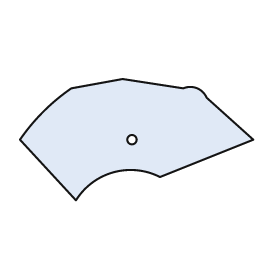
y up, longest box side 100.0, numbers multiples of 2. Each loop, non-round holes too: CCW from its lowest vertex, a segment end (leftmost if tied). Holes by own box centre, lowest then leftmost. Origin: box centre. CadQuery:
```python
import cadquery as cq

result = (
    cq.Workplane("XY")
    .moveTo(-26.0, -26.0)
    .threePointArc((-10.0, -14.0), (10.0, -16.0))
    .lineTo(50.0, 0.0)
    .lineTo(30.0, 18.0)
    .threePointArc((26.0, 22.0), (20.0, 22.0))
    .lineTo(-6.0, 26.0)
    .lineTo(-28.0, 22.0)
    .threePointArc((-40.0, 12.0), (-50.0, 0.0))
    .close()
    .moveTo(-2.0, 0.0)
    .circle(2.0)
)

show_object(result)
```